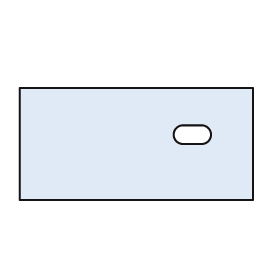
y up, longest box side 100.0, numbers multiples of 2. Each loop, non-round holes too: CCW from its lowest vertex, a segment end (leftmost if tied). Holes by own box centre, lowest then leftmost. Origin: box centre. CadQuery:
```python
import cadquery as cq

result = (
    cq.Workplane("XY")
    .moveTo(-50.0, -24.0)
    .lineTo(50.0, -24.0)
    .lineTo(50.0, 24.0)
    .lineTo(-50.0, 24.0)
    .close()
    .moveTo(20.0, 0.0)
    .lineTo(28.0, 0.0)
    .threePointArc((32.0, 4.0), (28.0, 8.0))
    .lineTo(20.0, 8.0)
    .threePointArc((16.0, 4.0), (20.0, 0.0))
    .close()
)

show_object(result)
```